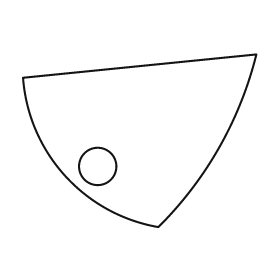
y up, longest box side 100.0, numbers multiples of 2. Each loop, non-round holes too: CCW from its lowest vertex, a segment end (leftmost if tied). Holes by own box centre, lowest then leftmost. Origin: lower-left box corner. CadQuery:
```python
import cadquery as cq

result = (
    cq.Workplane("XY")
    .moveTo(58.0, 0.0)
    .threePointArc((84.0, 34.0), (100.0, 74.0))
    .lineTo(0.0, 64.0)
    .threePointArc((18.0, 22.0), (58.0, 0.0))
    .close()
    .moveTo(32.0, 26.0)
    .circle(8.0)
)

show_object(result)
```